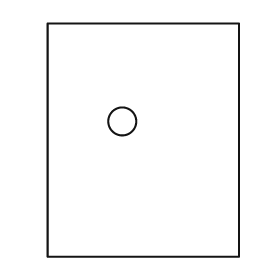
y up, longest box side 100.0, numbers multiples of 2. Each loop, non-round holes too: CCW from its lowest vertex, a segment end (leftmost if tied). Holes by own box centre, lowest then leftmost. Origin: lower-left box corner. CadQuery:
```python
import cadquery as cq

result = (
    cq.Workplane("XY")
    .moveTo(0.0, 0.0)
    .lineTo(82.0, 0.0)
    .lineTo(82.0, 100.0)
    .lineTo(0.0, 100.0)
    .close()
    .moveTo(32.0, 58.0)
    .circle(6.0)
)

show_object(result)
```